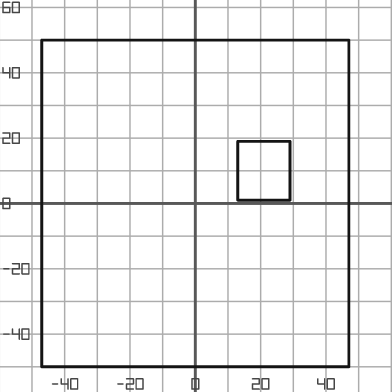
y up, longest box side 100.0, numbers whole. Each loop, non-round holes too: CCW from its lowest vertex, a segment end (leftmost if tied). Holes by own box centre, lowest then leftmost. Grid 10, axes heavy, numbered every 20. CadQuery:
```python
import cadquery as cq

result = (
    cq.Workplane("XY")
    .moveTo(-47.0, -50.0)
    .lineTo(47.0, -50.0)
    .lineTo(47.0, 50.0)
    .lineTo(-47.0, 50.0)
    .close()
    .moveTo(13.0, 1.0)
    .lineTo(29.0, 1.0)
    .lineTo(29.0, 19.0)
    .lineTo(13.0, 19.0)
    .close()
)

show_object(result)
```